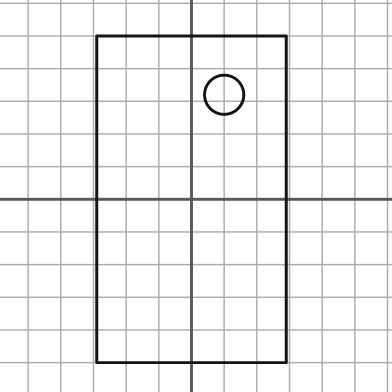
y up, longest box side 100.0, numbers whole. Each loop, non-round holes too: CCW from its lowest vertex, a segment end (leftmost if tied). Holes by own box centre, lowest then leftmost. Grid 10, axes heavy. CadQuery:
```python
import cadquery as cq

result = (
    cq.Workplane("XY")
    .moveTo(-29.0, -50.0)
    .lineTo(29.0, -50.0)
    .lineTo(29.0, 50.0)
    .lineTo(-29.0, 50.0)
    .close()
    .moveTo(10.0, 32.0)
    .circle(6.0)
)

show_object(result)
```